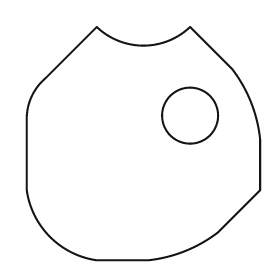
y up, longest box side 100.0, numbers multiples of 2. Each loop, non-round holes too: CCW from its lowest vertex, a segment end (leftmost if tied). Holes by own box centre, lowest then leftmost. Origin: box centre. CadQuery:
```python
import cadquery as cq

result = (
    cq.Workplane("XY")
    .moveTo(-20.0, -50.0)
    .lineTo(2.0, -50.0)
    .threePointArc((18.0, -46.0), (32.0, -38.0))
    .lineTo(50.0, -20.0)
    .lineTo(50.0, 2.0)
    .threePointArc((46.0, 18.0), (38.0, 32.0))
    .lineTo(20.0, 50.0)
    .threePointArc((0.0, 42.0), (-20.0, 50.0))
    .lineTo(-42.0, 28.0)
    .threePointArc((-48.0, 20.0), (-50.0, 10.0))
    .lineTo(-50.0, -20.0)
    .threePointArc((-40.0, -40.0), (-20.0, -50.0))
    .close()
    .moveTo(20.0, 12.0)
    .circle(12.0)
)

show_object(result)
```